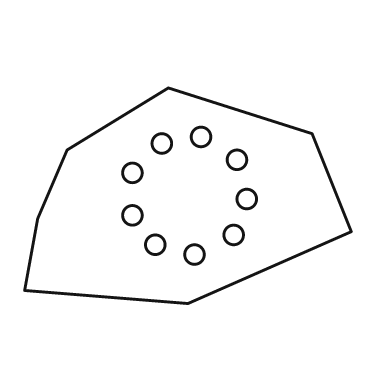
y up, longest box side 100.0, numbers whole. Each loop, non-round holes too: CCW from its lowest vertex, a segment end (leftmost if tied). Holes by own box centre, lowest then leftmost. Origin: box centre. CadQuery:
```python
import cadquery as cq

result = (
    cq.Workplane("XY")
    .moveTo(0.0, -33.0)
    .lineTo(50.0, -11.0)
    .lineTo(38.0, 19.0)
    .lineTo(-6.0, 33.0)
    .lineTo(-37.0, 14.0)
    .lineTo(-46.0, -7.0)
    .lineTo(-50.0, -29.0)
    .close()
    .moveTo(2.0, -18.0)
    .circle(3.0)
    .moveTo(-10.0, -15.0)
    .circle(3.0)
    .moveTo(14.0, -12.0)
    .circle(3.0)
    .moveTo(-17.0, -6.0)
    .circle(3.0)
    .moveTo(18.0, -1.0)
    .circle(3.0)
    .moveTo(-17.0, 7.0)
    .circle(3.0)
    .moveTo(15.0, 11.0)
    .circle(3.0)
    .moveTo(-8.0, 16.0)
    .circle(3.0)
    .moveTo(4.0, 18.0)
    .circle(3.0)
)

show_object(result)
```